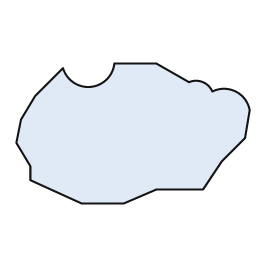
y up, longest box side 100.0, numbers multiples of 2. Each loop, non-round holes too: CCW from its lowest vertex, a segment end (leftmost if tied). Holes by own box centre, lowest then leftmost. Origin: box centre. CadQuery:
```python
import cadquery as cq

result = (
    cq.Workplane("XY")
    .moveTo(-22.0, -30.0)
    .lineTo(-4.0, -30.0)
    .lineTo(10.0, -24.0)
    .lineTo(30.0, -24.0)
    .lineTo(38.0, -12.0)
    .lineTo(48.0, -2.0)
    .lineTo(50.0, 10.0)
    .threePointArc((44.0, 18.0), (34.0, 18.0))
    .threePointArc((30.0, 22.0), (24.0, 22.0))
    .lineTo(10.0, 30.0)
    .lineTo(-8.0, 30.0)
    .threePointArc((-18.0, 20.0), (-30.0, 28.0))
    .lineTo(-42.0, 16.0)
    .lineTo(-48.0, 6.0)
    .lineTo(-50.0, -4.0)
    .lineTo(-44.0, -14.0)
    .lineTo(-44.0, -20.0)
    .close()
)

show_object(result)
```